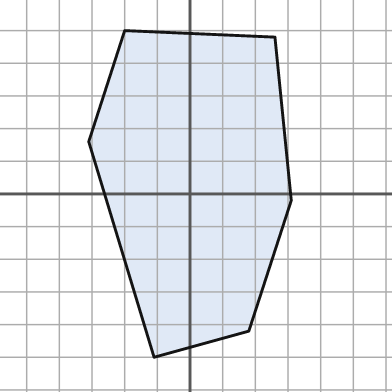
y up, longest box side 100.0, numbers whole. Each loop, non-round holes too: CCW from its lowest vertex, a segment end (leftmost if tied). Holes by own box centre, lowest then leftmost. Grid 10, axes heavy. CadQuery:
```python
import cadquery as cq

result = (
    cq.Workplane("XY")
    .moveTo(-11.0, -50.0)
    .lineTo(18.0, -42.0)
    .lineTo(31.0, -2.0)
    .lineTo(26.0, 48.0)
    .lineTo(-20.0, 50.0)
    .lineTo(-31.0, 16.0)
    .close()
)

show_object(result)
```